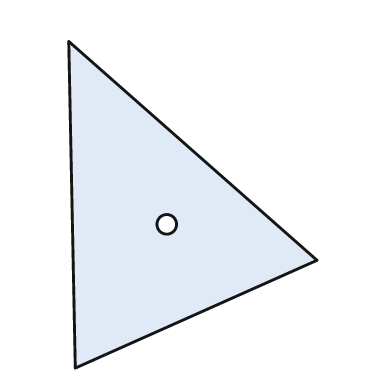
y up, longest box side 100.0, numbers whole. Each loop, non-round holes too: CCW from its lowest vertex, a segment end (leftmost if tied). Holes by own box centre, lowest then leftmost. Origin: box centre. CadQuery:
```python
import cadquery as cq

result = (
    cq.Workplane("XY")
    .moveTo(-36.0, -50.0)
    .lineTo(38.0, -17.0)
    .lineTo(-38.0, 50.0)
    .close()
    .moveTo(-8.0, -6.0)
    .circle(3.0)
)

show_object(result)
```